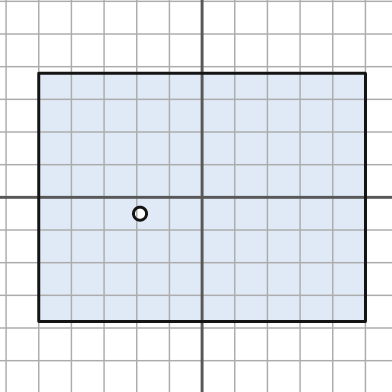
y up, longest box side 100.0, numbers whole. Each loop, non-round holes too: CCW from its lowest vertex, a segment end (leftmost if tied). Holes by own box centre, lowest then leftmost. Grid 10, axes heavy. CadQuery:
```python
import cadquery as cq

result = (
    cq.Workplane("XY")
    .moveTo(-50.0, -38.0)
    .lineTo(50.0, -38.0)
    .lineTo(50.0, 38.0)
    .lineTo(-50.0, 38.0)
    .close()
    .moveTo(-19.0, -5.0)
    .circle(2.0)
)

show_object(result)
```